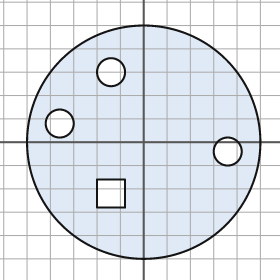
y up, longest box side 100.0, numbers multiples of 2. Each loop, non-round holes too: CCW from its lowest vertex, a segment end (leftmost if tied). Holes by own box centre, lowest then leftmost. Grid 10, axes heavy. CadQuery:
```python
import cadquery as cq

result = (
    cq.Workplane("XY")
    .moveTo(0.0, 0.0)
    .circle(50.0)
    .moveTo(-20.0, -28.0)
    .lineTo(-8.0, -28.0)
    .lineTo(-8.0, -16.0)
    .lineTo(-20.0, -16.0)
    .close()
    .moveTo(36.0, -4.0)
    .circle(6.0)
    .moveTo(-36.0, 8.0)
    .circle(6.0)
    .moveTo(-14.0, 30.0)
    .circle(6.0)
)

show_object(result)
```